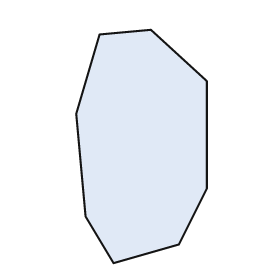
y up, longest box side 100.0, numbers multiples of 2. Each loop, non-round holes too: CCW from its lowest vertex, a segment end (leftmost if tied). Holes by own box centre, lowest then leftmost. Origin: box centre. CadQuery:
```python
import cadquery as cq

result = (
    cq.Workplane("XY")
    .moveTo(-12.0, -50.0)
    .lineTo(16.0, -42.0)
    .lineTo(28.0, -18.0)
    .lineTo(28.0, 28.0)
    .lineTo(4.0, 50.0)
    .lineTo(-18.0, 48.0)
    .lineTo(-28.0, 14.0)
    .lineTo(-24.0, -30.0)
    .close()
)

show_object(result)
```